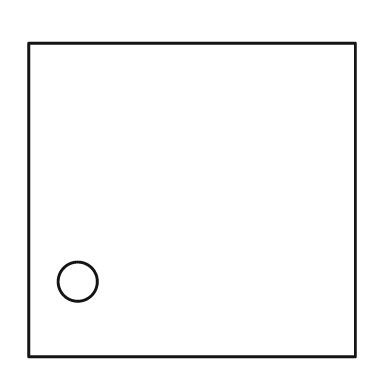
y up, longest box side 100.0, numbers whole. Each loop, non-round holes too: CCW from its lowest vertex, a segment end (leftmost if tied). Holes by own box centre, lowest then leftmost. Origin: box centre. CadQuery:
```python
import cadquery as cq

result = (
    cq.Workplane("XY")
    .moveTo(-50.0, -48.0)
    .lineTo(50.0, -48.0)
    .lineTo(50.0, 48.0)
    .lineTo(-50.0, 48.0)
    .close()
    .moveTo(-35.0, -25.0)
    .circle(6.0)
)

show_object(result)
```